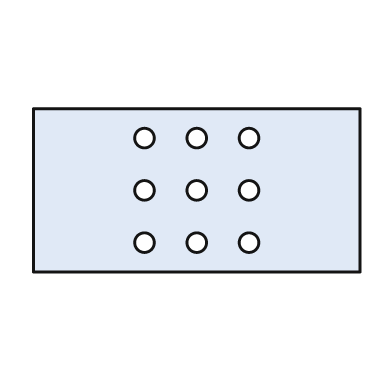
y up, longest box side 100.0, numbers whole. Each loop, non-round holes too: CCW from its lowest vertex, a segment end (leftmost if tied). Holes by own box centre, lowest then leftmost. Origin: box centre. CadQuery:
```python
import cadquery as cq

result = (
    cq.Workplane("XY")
    .moveTo(-50.0, -25.0)
    .lineTo(50.0, -25.0)
    .lineTo(50.0, 25.0)
    .lineTo(-50.0, 25.0)
    .close()
    .moveTo(-16.0, -16.0)
    .circle(3.0)
    .moveTo(0.0, -16.0)
    .circle(3.0)
    .moveTo(16.0, -16.0)
    .circle(3.0)
    .moveTo(-16.0, 0.0)
    .circle(3.0)
    .moveTo(0.0, 0.0)
    .circle(3.0)
    .moveTo(16.0, 0.0)
    .circle(3.0)
    .moveTo(-16.0, 16.0)
    .circle(3.0)
    .moveTo(0.0, 16.0)
    .circle(3.0)
    .moveTo(16.0, 16.0)
    .circle(3.0)
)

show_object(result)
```